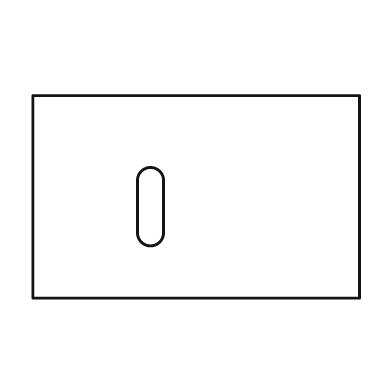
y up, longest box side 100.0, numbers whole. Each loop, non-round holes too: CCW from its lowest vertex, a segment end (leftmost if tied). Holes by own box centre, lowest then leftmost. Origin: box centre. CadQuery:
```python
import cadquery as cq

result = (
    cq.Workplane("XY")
    .moveTo(-50.0, -31.0)
    .lineTo(50.0, -31.0)
    .lineTo(50.0, 31.0)
    .lineTo(-50.0, 31.0)
    .close()
    .moveTo(-18.0, -11.0)
    .threePointArc((-14.0, -15.0), (-10.0, -11.0))
    .lineTo(-10.0, 5.0)
    .threePointArc((-14.0, 9.0), (-18.0, 5.0))
    .close()
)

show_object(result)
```